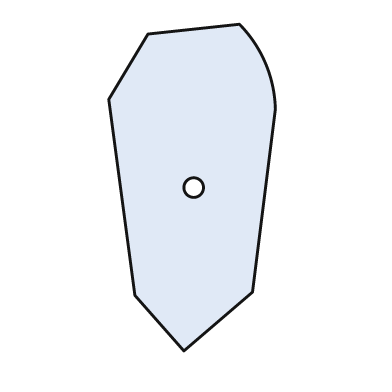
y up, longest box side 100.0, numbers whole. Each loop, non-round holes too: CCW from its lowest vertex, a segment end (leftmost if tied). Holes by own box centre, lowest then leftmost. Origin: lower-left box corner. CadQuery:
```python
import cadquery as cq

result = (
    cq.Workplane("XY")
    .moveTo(23.0, 0.0)
    .lineTo(44.0, 18.0)
    .lineTo(51.0, 74.0)
    .threePointArc((48.0, 88.0), (40.0, 100.0))
    .lineTo(12.0, 97.0)
    .lineTo(0.0, 77.0)
    .lineTo(8.0, 17.0)
    .close()
    .moveTo(26.0, 50.0)
    .circle(3.0)
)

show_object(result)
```